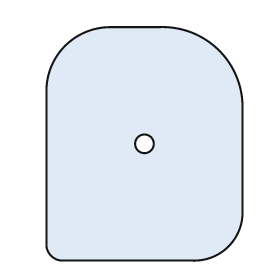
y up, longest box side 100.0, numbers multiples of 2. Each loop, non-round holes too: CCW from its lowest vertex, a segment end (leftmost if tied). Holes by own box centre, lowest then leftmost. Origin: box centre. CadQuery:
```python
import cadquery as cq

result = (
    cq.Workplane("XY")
    .moveTo(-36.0, -50.0)
    .lineTo(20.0, -50.0)
    .threePointArc((36.0, -44.0), (42.0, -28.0))
    .lineTo(42.0, 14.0)
    .threePointArc((32.0, 40.0), (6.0, 50.0))
    .lineTo(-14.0, 50.0)
    .threePointArc((-34.0, 42.0), (-42.0, 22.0))
    .lineTo(-42.0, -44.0)
    .threePointArc((-40.0, -48.0), (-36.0, -50.0))
    .close()
    .moveTo(0.0, 0.0)
    .circle(4.0)
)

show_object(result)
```